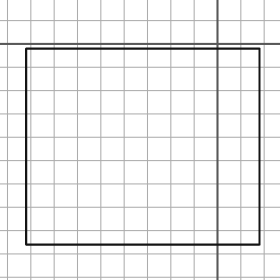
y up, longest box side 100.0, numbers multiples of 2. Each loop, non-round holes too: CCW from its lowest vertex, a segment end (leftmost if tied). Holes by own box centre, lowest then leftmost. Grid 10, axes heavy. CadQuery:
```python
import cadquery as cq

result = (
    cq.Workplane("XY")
    .moveTo(-82.0, -86.0)
    .lineTo(18.0, -86.0)
    .lineTo(18.0, -2.0)
    .lineTo(-82.0, -2.0)
    .close()
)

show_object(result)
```